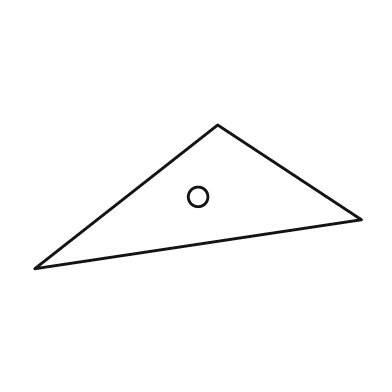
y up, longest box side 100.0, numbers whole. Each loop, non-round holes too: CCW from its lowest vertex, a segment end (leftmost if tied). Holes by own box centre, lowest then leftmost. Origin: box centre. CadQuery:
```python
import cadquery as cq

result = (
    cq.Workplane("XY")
    .moveTo(-50.0, -22.0)
    .lineTo(50.0, -7.0)
    .lineTo(6.0, 22.0)
    .close()
    .moveTo(0.0, 0.0)
    .circle(3.0)
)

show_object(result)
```